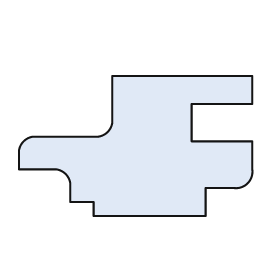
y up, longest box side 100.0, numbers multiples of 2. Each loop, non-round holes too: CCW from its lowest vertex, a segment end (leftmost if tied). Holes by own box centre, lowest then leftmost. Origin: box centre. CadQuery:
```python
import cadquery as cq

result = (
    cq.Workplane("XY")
    .moveTo(-18.0, -30.0)
    .lineTo(30.0, -30.0)
    .lineTo(30.0, -18.0)
    .lineTo(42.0, -18.0)
    .threePointArc((48.0, -16.0), (50.0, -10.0))
    .lineTo(50.0, 2.0)
    .lineTo(24.0, 2.0)
    .lineTo(24.0, 18.0)
    .lineTo(50.0, 18.0)
    .lineTo(50.0, 30.0)
    .lineTo(-10.0, 30.0)
    .lineTo(-10.0, 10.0)
    .threePointArc((-12.0, 6.0), (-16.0, 4.0))
    .lineTo(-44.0, 4.0)
    .threePointArc((-48.0, 2.0), (-50.0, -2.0))
    .lineTo(-50.0, -10.0)
    .lineTo(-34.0, -10.0)
    .threePointArc((-30.0, -12.0), (-28.0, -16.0))
    .lineTo(-28.0, -24.0)
    .lineTo(-18.0, -24.0)
    .close()
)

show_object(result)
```